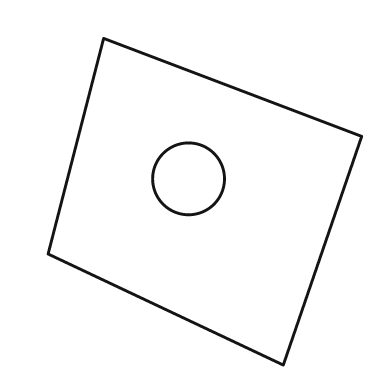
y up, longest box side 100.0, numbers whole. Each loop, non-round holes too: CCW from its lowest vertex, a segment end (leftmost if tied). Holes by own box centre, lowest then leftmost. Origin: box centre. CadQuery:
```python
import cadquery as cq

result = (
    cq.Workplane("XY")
    .moveTo(24.0, -50.0)
    .lineTo(48.0, 20.0)
    .lineTo(-31.0, 50.0)
    .lineTo(-48.0, -16.0)
    .close()
    .moveTo(-5.0, 7.0)
    .circle(11.0)
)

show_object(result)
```